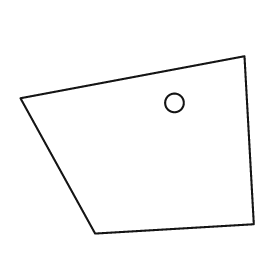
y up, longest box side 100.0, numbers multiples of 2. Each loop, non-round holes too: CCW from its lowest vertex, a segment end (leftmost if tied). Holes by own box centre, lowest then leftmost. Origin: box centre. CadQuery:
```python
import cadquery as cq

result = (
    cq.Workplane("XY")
    .moveTo(-18.0, -38.0)
    .lineTo(50.0, -34.0)
    .lineTo(46.0, 38.0)
    .lineTo(-50.0, 20.0)
    .close()
    .moveTo(16.0, 18.0)
    .circle(4.0)
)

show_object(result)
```